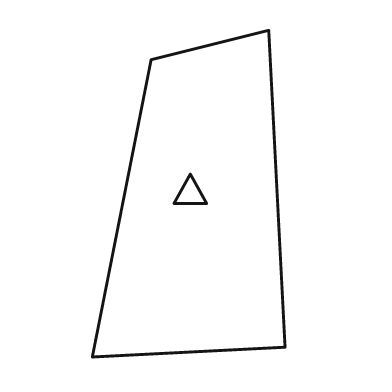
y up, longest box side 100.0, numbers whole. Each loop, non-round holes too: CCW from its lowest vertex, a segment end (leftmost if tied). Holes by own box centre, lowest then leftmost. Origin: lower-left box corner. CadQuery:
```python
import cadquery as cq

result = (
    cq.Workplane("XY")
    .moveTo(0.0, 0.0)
    .lineTo(59.0, 3.0)
    .lineTo(54.0, 100.0)
    .lineTo(18.0, 91.0)
    .close()
    .moveTo(25.0, 47.0)
    .lineTo(35.0, 47.0)
    .lineTo(30.0, 56.0)
    .close()
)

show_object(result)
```